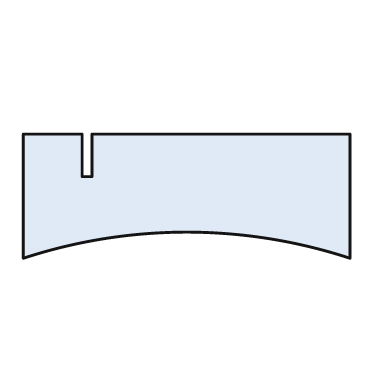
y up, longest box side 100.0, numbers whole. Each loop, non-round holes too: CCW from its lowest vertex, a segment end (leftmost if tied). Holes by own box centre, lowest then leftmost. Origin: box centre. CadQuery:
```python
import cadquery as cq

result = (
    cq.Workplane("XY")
    .moveTo(-50.0, -19.0)
    .threePointArc((0.0, -11.0), (50.0, -19.0))
    .lineTo(50.0, 19.0)
    .lineTo(-29.0, 19.0)
    .lineTo(-29.0, 6.0)
    .lineTo(-32.0, 6.0)
    .lineTo(-32.0, 19.0)
    .lineTo(-50.0, 19.0)
    .close()
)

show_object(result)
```